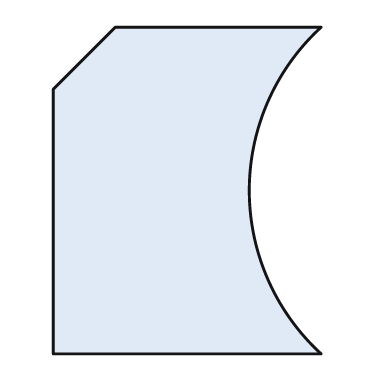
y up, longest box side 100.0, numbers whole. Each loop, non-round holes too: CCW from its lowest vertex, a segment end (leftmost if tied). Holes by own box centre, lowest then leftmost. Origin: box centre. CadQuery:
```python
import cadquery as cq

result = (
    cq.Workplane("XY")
    .moveTo(-41.0, -50.0)
    .lineTo(41.0, -50.0)
    .threePointArc((19.0, 0.0), (41.0, 50.0))
    .lineTo(-22.0, 50.0)
    .lineTo(-41.0, 31.0)
    .close()
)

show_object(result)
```